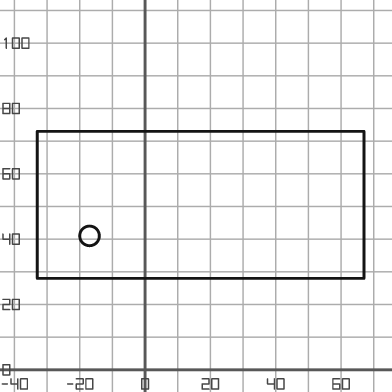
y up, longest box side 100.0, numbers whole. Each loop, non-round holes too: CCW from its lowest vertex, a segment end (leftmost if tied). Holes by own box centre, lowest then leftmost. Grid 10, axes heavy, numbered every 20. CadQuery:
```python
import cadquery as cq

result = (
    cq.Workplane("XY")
    .moveTo(-33.0, 28.0)
    .lineTo(67.0, 28.0)
    .lineTo(67.0, 73.0)
    .lineTo(-33.0, 73.0)
    .close()
    .moveTo(-17.0, 41.0)
    .circle(3.0)
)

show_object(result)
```